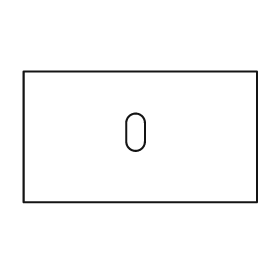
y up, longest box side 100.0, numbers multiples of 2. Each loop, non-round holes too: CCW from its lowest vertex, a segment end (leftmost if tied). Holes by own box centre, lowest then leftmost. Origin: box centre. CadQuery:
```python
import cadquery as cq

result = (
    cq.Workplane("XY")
    .moveTo(-50.0, -28.0)
    .lineTo(50.0, -28.0)
    .lineTo(50.0, 28.0)
    .lineTo(-50.0, 28.0)
    .close()
    .moveTo(-6.0, -2.0)
    .threePointArc((-2.0, -6.0), (2.0, -2.0))
    .lineTo(2.0, 6.0)
    .threePointArc((-2.0, 10.0), (-6.0, 6.0))
    .close()
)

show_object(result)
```